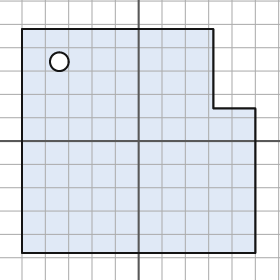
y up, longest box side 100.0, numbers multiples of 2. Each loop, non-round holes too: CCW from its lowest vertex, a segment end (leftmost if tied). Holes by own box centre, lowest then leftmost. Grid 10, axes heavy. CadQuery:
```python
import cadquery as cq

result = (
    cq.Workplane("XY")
    .moveTo(-50.0, -48.0)
    .lineTo(50.0, -48.0)
    .lineTo(50.0, 14.0)
    .lineTo(32.0, 14.0)
    .lineTo(32.0, 48.0)
    .lineTo(-50.0, 48.0)
    .close()
    .moveTo(-34.0, 34.0)
    .circle(4.0)
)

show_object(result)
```